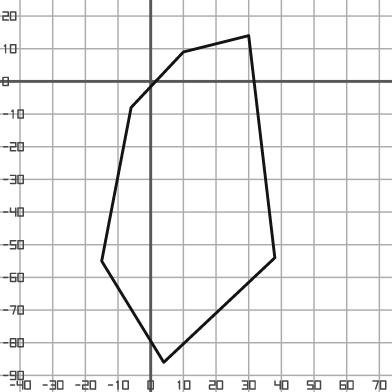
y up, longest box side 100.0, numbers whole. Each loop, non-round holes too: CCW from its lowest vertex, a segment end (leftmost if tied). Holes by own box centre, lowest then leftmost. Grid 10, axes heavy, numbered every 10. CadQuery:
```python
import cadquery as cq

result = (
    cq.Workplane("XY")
    .moveTo(4.0, -86.0)
    .lineTo(38.0, -54.0)
    .lineTo(30.0, 14.0)
    .lineTo(10.0, 9.0)
    .lineTo(-6.0, -8.0)
    .lineTo(-15.0, -55.0)
    .close()
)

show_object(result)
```